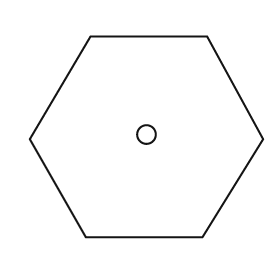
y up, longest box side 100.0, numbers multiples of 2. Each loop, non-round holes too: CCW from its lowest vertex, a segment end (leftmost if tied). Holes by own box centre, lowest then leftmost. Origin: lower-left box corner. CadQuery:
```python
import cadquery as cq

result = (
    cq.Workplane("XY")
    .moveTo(24.0, 0.0)
    .lineTo(74.0, 0.0)
    .lineTo(100.0, 42.0)
    .lineTo(76.0, 86.0)
    .lineTo(26.0, 86.0)
    .lineTo(0.0, 42.0)
    .close()
    .moveTo(50.0, 44.0)
    .circle(4.0)
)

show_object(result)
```